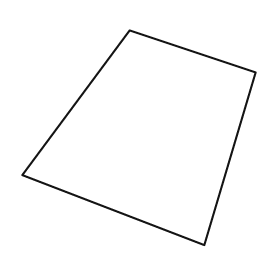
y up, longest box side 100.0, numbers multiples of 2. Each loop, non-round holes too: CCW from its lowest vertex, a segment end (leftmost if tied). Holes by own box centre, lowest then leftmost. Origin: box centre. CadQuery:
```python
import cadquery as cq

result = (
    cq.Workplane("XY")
    .moveTo(28.0, -46.0)
    .lineTo(50.0, 28.0)
    .lineTo(-4.0, 46.0)
    .lineTo(-50.0, -16.0)
    .close()
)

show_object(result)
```